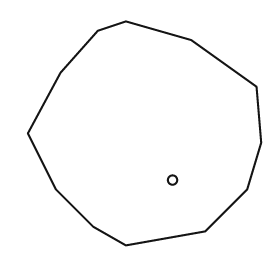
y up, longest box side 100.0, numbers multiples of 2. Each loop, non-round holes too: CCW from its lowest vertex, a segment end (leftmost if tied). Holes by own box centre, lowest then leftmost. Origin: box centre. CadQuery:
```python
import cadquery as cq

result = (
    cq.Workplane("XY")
    .moveTo(-8.0, -48.0)
    .lineTo(26.0, -42.0)
    .lineTo(44.0, -24.0)
    .lineTo(50.0, -4.0)
    .lineTo(48.0, 20.0)
    .lineTo(20.0, 40.0)
    .lineTo(-8.0, 48.0)
    .lineTo(-20.0, 44.0)
    .lineTo(-36.0, 26.0)
    .lineTo(-50.0, 0.0)
    .lineTo(-38.0, -24.0)
    .lineTo(-22.0, -40.0)
    .close()
    .moveTo(12.0, -20.0)
    .circle(2.0)
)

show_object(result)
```